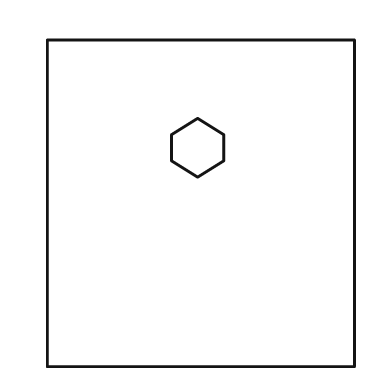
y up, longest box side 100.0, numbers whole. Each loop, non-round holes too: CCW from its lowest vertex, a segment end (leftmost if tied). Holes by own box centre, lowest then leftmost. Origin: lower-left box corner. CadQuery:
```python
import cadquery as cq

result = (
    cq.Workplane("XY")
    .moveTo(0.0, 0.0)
    .lineTo(94.0, 0.0)
    .lineTo(94.0, 100.0)
    .lineTo(0.0, 100.0)
    .close()
    .moveTo(46.0, 58.0)
    .lineTo(54.0, 63.0)
    .lineTo(54.0, 71.0)
    .lineTo(46.0, 76.0)
    .lineTo(38.0, 71.0)
    .lineTo(38.0, 63.0)
    .close()
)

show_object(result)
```